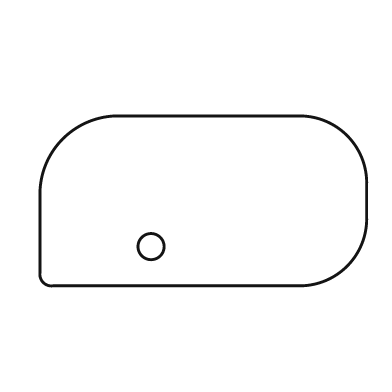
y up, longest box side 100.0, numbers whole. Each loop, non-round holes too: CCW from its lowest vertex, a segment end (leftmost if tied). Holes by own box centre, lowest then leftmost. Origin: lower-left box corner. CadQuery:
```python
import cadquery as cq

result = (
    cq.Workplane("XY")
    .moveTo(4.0, 0.0)
    .lineTo(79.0, 0.0)
    .threePointArc((94.0, 6.0), (100.0, 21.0))
    .lineTo(100.0, 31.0)
    .threePointArc((94.0, 46.0), (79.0, 52.0))
    .lineTo(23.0, 52.0)
    .threePointArc((7.0, 45.0), (0.0, 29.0))
    .lineTo(0.0, 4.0)
    .threePointArc((1.0, 1.0), (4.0, 0.0))
    .close()
    .moveTo(34.0, 12.0)
    .circle(4.0)
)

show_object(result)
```